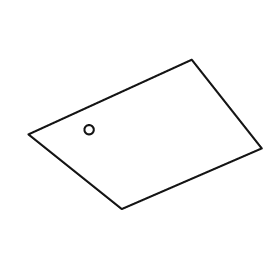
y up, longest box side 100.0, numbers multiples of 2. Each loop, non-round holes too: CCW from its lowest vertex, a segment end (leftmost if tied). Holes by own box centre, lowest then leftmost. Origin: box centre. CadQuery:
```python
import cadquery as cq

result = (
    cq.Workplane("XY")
    .moveTo(-10.0, -32.0)
    .lineTo(50.0, -6.0)
    .lineTo(20.0, 32.0)
    .lineTo(-50.0, 0.0)
    .close()
    .moveTo(-24.0, 2.0)
    .circle(2.0)
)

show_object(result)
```